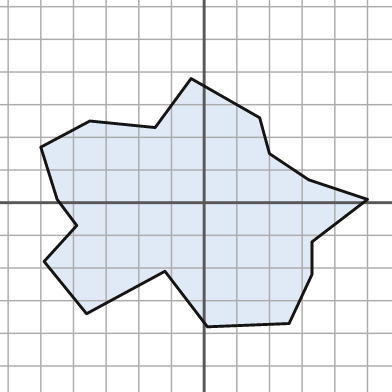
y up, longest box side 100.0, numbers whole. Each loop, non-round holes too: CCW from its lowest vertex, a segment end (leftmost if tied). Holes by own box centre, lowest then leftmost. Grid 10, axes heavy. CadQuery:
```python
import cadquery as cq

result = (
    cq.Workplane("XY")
    .moveTo(1.0, -38.0)
    .lineTo(26.0, -37.0)
    .lineTo(33.0, -22.0)
    .lineTo(33.0, -12.0)
    .lineTo(50.0, 1.0)
    .lineTo(32.0, 7.0)
    .lineTo(20.0, 15.0)
    .lineTo(17.0, 26.0)
    .lineTo(-4.0, 38.0)
    .lineTo(-15.0, 23.0)
    .lineTo(-35.0, 25.0)
    .lineTo(-50.0, 17.0)
    .lineTo(-45.0, 1.0)
    .lineTo(-39.0, -7.0)
    .lineTo(-49.0, -18.0)
    .lineTo(-36.0, -34.0)
    .lineTo(-12.0, -21.0)
    .close()
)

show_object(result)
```